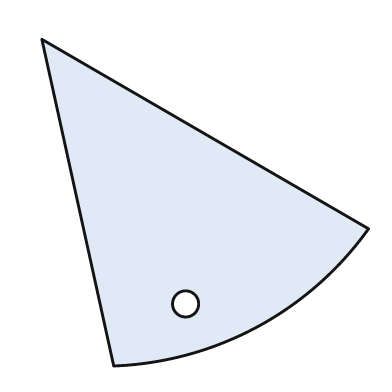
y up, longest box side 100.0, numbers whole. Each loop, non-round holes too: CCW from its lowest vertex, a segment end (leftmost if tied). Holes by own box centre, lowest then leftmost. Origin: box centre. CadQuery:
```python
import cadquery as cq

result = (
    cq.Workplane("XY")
    .moveTo(-28.0, -50.0)
    .threePointArc((16.0, -38.0), (50.0, -8.0))
    .lineTo(-50.0, 50.0)
    .close()
    .moveTo(-6.0, -31.0)
    .circle(4.0)
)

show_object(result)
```